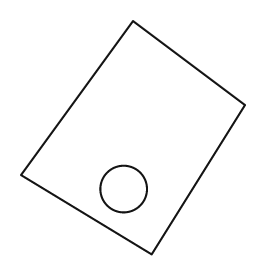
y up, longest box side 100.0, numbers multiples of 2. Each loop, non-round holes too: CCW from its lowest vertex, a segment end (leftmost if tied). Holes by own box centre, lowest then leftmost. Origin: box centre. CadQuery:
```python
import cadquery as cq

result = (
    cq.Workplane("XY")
    .moveTo(8.0, -50.0)
    .lineTo(48.0, 14.0)
    .lineTo(0.0, 50.0)
    .lineTo(-48.0, -16.0)
    .close()
    .moveTo(-4.0, -22.0)
    .circle(10.0)
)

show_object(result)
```